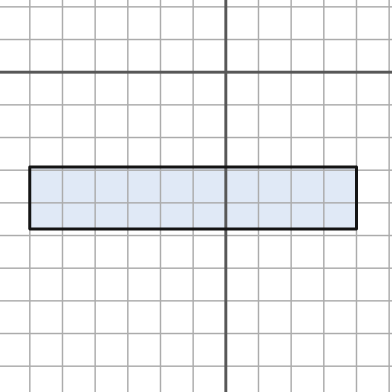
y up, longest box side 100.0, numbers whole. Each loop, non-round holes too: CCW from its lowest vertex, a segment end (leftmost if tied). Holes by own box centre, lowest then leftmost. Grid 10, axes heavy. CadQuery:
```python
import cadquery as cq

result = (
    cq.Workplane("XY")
    .moveTo(-60.0, -48.0)
    .lineTo(40.0, -48.0)
    .lineTo(40.0, -29.0)
    .lineTo(-60.0, -29.0)
    .close()
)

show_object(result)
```